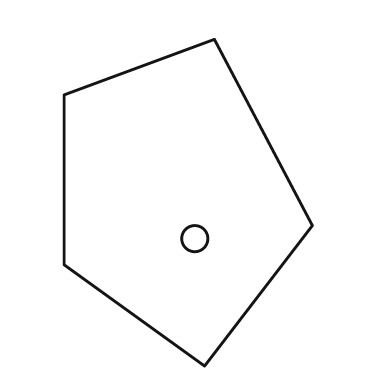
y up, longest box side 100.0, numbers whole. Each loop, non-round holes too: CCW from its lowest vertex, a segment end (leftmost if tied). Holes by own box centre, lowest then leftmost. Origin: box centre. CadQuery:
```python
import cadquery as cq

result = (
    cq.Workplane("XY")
    .moveTo(5.0, -50.0)
    .lineTo(38.0, -7.0)
    .lineTo(8.0, 50.0)
    .lineTo(-38.0, 33.0)
    .lineTo(-38.0, -19.0)
    .close()
    .moveTo(2.0, -11.0)
    .circle(4.0)
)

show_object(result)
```